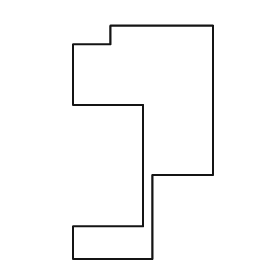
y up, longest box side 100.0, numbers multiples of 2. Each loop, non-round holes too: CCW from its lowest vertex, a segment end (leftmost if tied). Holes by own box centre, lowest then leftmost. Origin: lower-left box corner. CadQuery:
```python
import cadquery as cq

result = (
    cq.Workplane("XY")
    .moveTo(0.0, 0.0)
    .lineTo(34.0, 0.0)
    .lineTo(34.0, 36.0)
    .lineTo(60.0, 36.0)
    .lineTo(60.0, 100.0)
    .lineTo(16.0, 100.0)
    .lineTo(16.0, 92.0)
    .lineTo(0.0, 92.0)
    .lineTo(0.0, 66.0)
    .lineTo(30.0, 66.0)
    .lineTo(30.0, 14.0)
    .lineTo(0.0, 14.0)
    .close()
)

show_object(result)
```